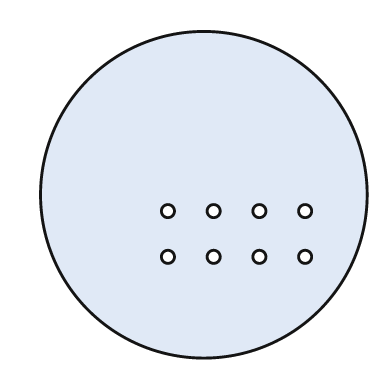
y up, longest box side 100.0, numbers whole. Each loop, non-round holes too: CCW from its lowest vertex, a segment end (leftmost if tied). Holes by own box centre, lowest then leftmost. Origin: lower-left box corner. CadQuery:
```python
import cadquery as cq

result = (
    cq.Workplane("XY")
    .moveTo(50.0, 50.0)
    .circle(50.0)
    .moveTo(39.0, 31.0)
    .circle(2.0)
    .moveTo(53.0, 31.0)
    .circle(2.0)
    .moveTo(67.0, 31.0)
    .circle(2.0)
    .moveTo(81.0, 31.0)
    .circle(2.0)
    .moveTo(39.0, 45.0)
    .circle(2.0)
    .moveTo(53.0, 45.0)
    .circle(2.0)
    .moveTo(67.0, 45.0)
    .circle(2.0)
    .moveTo(81.0, 45.0)
    .circle(2.0)
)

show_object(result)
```